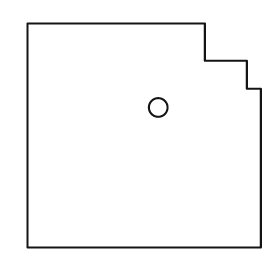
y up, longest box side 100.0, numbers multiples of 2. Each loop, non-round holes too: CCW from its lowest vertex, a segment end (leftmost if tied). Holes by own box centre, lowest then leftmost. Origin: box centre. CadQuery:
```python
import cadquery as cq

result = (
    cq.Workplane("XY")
    .moveTo(-50.0, -48.0)
    .lineTo(50.0, -48.0)
    .lineTo(50.0, 20.0)
    .lineTo(44.0, 20.0)
    .lineTo(44.0, 32.0)
    .lineTo(26.0, 32.0)
    .lineTo(26.0, 48.0)
    .lineTo(-50.0, 48.0)
    .close()
    .moveTo(6.0, 12.0)
    .circle(4.0)
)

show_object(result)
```